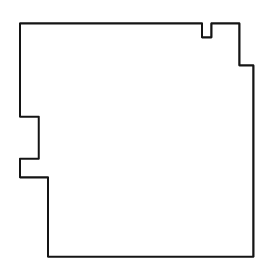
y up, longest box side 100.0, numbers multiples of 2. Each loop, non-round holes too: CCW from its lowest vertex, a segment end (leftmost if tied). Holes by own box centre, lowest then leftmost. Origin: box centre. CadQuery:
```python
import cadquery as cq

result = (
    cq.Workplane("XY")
    .moveTo(-38.0, -50.0)
    .lineTo(50.0, -50.0)
    .lineTo(50.0, 32.0)
    .lineTo(44.0, 32.0)
    .lineTo(44.0, 50.0)
    .lineTo(32.0, 50.0)
    .lineTo(32.0, 44.0)
    .lineTo(28.0, 44.0)
    .lineTo(28.0, 50.0)
    .lineTo(-50.0, 50.0)
    .lineTo(-50.0, 10.0)
    .lineTo(-42.0, 10.0)
    .lineTo(-42.0, -8.0)
    .lineTo(-50.0, -8.0)
    .lineTo(-50.0, -16.0)
    .lineTo(-38.0, -16.0)
    .close()
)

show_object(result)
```